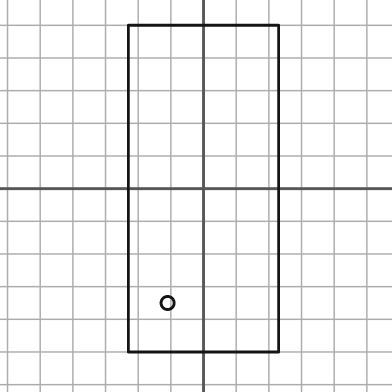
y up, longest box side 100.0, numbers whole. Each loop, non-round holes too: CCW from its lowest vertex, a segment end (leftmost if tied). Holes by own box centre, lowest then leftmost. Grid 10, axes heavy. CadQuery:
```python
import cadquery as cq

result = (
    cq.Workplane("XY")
    .moveTo(-23.0, -50.0)
    .lineTo(23.0, -50.0)
    .lineTo(23.0, 50.0)
    .lineTo(-23.0, 50.0)
    .close()
    .moveTo(-11.0, -35.0)
    .circle(2.0)
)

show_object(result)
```